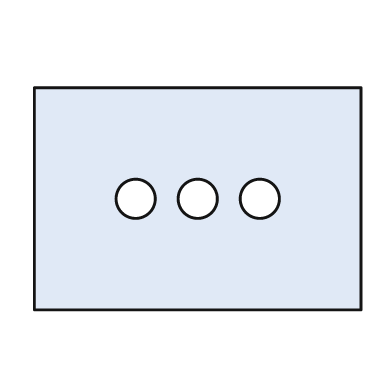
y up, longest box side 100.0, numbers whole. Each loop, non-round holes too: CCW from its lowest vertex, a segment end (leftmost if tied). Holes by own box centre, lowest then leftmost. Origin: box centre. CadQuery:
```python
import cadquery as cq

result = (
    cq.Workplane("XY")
    .moveTo(-50.0, -34.0)
    .lineTo(50.0, -34.0)
    .lineTo(50.0, 34.0)
    .lineTo(-50.0, 34.0)
    .close()
    .moveTo(-19.0, 0.0)
    .circle(6.0)
    .moveTo(0.0, 0.0)
    .circle(6.0)
    .moveTo(19.0, 0.0)
    .circle(6.0)
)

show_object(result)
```